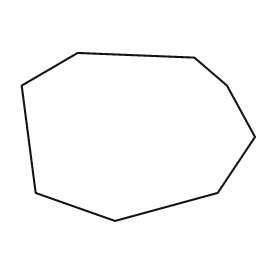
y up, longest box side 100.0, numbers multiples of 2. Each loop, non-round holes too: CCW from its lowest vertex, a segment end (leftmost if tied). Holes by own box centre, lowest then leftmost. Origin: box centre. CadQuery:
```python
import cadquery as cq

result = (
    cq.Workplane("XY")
    .moveTo(-10.0, -36.0)
    .lineTo(34.0, -24.0)
    .lineTo(50.0, 0.0)
    .lineTo(38.0, 22.0)
    .lineTo(24.0, 34.0)
    .lineTo(-26.0, 36.0)
    .lineTo(-50.0, 22.0)
    .lineTo(-44.0, -24.0)
    .close()
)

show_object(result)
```